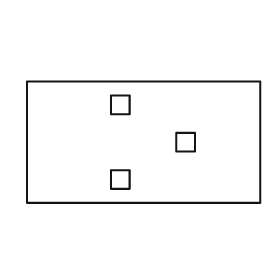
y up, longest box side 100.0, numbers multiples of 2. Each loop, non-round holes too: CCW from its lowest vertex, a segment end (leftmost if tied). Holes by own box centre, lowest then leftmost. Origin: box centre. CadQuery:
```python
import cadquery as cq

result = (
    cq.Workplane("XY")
    .moveTo(-50.0, -26.0)
    .lineTo(50.0, -26.0)
    .lineTo(50.0, 26.0)
    .lineTo(-50.0, 26.0)
    .close()
    .moveTo(-14.0, -20.0)
    .lineTo(-6.0, -20.0)
    .lineTo(-6.0, -12.0)
    .lineTo(-14.0, -12.0)
    .close()
    .moveTo(14.0, -4.0)
    .lineTo(22.0, -4.0)
    .lineTo(22.0, 4.0)
    .lineTo(14.0, 4.0)
    .close()
    .moveTo(-14.0, 12.0)
    .lineTo(-6.0, 12.0)
    .lineTo(-6.0, 20.0)
    .lineTo(-14.0, 20.0)
    .close()
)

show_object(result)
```